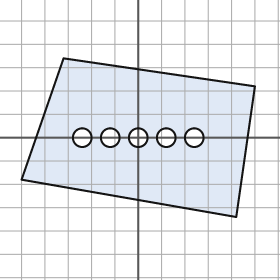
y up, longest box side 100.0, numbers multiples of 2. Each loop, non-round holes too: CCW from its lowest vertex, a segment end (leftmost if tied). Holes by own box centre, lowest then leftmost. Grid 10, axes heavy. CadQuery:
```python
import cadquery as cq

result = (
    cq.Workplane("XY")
    .moveTo(42.0, -34.0)
    .lineTo(50.0, 22.0)
    .lineTo(-32.0, 34.0)
    .lineTo(-50.0, -18.0)
    .close()
    .moveTo(-24.0, 0.0)
    .circle(4.0)
    .moveTo(-12.0, 0.0)
    .circle(4.0)
    .moveTo(0.0, 0.0)
    .circle(4.0)
    .moveTo(12.0, 0.0)
    .circle(4.0)
    .moveTo(24.0, 0.0)
    .circle(4.0)
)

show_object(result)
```